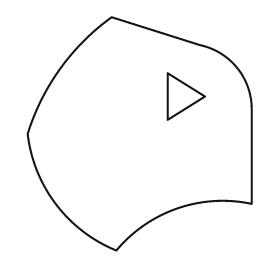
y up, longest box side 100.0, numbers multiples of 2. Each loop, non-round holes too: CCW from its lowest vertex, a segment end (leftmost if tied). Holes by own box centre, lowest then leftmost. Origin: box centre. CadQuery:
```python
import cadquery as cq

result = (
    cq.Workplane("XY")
    .moveTo(-10.0, -50.0)
    .threePointArc((16.0, -32.0), (48.0, -30.0))
    .lineTo(48.0, 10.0)
    .threePointArc((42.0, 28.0), (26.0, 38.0))
    .lineTo(-12.0, 50.0)
    .threePointArc((-34.0, 28.0), (-48.0, 0.0))
    .threePointArc((-36.0, -30.0), (-10.0, -50.0))
    .close()
    .moveTo(12.0, 6.0)
    .lineTo(28.0, 16.0)
    .lineTo(12.0, 26.0)
    .close()
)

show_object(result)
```